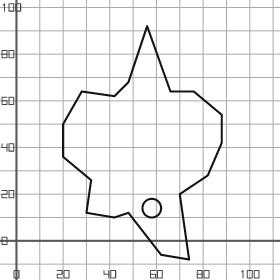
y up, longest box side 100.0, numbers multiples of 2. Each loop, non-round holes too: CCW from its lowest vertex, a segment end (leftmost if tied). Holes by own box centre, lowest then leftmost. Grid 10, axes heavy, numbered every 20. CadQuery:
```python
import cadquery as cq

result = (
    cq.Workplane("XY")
    .moveTo(74.0, -8.0)
    .lineTo(70.0, 20.0)
    .lineTo(82.0, 28.0)
    .lineTo(88.0, 42.0)
    .lineTo(88.0, 54.0)
    .lineTo(76.0, 64.0)
    .lineTo(66.0, 64.0)
    .lineTo(56.0, 92.0)
    .lineTo(48.0, 68.0)
    .lineTo(42.0, 62.0)
    .lineTo(28.0, 64.0)
    .lineTo(20.0, 50.0)
    .lineTo(20.0, 36.0)
    .lineTo(32.0, 26.0)
    .lineTo(30.0, 12.0)
    .lineTo(42.0, 10.0)
    .lineTo(48.0, 12.0)
    .lineTo(62.0, -6.0)
    .close()
    .moveTo(58.0, 14.0)
    .circle(4.0)
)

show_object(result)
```